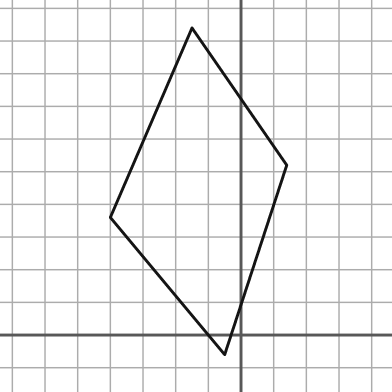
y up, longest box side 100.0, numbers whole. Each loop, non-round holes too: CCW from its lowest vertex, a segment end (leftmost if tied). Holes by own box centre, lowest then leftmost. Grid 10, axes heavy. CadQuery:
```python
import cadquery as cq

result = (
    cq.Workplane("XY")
    .moveTo(-5.0, -6.0)
    .lineTo(14.0, 52.0)
    .lineTo(-15.0, 94.0)
    .lineTo(-40.0, 36.0)
    .close()
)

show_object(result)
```